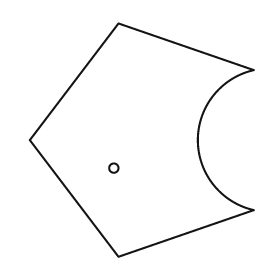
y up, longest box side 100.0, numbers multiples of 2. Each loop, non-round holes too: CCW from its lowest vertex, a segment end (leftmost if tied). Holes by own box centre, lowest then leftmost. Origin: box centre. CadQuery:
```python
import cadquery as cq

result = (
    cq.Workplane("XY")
    .moveTo(-10.0, -50.0)
    .lineTo(48.0, -30.0)
    .threePointArc((24.0, 0.0), (48.0, 30.0))
    .lineTo(-10.0, 50.0)
    .lineTo(-48.0, 0.0)
    .close()
    .moveTo(-12.0, -12.0)
    .circle(2.0)
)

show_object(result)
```